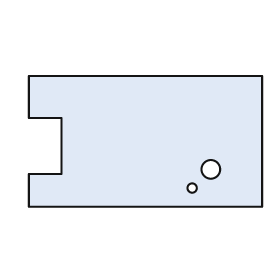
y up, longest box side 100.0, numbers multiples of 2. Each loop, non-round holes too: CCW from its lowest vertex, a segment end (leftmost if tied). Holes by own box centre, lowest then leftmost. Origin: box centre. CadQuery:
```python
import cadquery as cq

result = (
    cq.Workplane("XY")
    .moveTo(-50.0, -28.0)
    .lineTo(50.0, -28.0)
    .lineTo(50.0, 28.0)
    .lineTo(-50.0, 28.0)
    .lineTo(-50.0, 10.0)
    .lineTo(-36.0, 10.0)
    .lineTo(-36.0, -14.0)
    .lineTo(-50.0, -14.0)
    .close()
    .moveTo(20.0, -20.0)
    .circle(2.0)
    .moveTo(28.0, -12.0)
    .circle(4.0)
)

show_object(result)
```